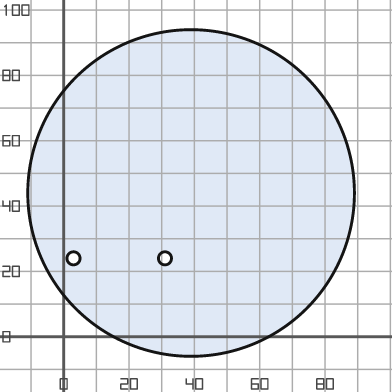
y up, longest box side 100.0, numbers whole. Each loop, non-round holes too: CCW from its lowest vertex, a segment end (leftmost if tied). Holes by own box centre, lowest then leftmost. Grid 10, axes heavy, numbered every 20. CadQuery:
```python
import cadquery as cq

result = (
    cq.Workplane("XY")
    .moveTo(39.0, 44.0)
    .circle(50.0)
    .moveTo(3.0, 24.0)
    .circle(2.0)
    .moveTo(31.0, 24.0)
    .circle(2.0)
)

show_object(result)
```